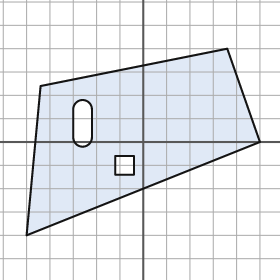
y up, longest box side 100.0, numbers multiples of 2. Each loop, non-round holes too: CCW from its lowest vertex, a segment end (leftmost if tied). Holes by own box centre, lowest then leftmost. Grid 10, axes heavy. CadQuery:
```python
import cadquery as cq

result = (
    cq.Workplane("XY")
    .moveTo(-50.0, -40.0)
    .lineTo(50.0, 0.0)
    .lineTo(36.0, 40.0)
    .lineTo(-44.0, 24.0)
    .close()
    .moveTo(-12.0, -14.0)
    .lineTo(-4.0, -14.0)
    .lineTo(-4.0, -6.0)
    .lineTo(-12.0, -6.0)
    .close()
    .moveTo(-30.0, 2.0)
    .threePointArc((-26.0, -2.0), (-22.0, 2.0))
    .lineTo(-22.0, 14.0)
    .threePointArc((-26.0, 18.0), (-30.0, 14.0))
    .close()
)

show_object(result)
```